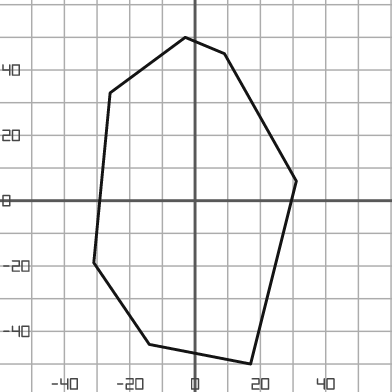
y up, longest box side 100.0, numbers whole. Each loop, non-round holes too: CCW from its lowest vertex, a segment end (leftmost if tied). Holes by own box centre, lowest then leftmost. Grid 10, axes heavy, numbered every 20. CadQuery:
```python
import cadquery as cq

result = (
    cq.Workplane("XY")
    .moveTo(17.0, -50.0)
    .lineTo(31.0, 6.0)
    .lineTo(9.0, 45.0)
    .lineTo(-3.0, 50.0)
    .lineTo(-26.0, 33.0)
    .lineTo(-31.0, -19.0)
    .lineTo(-14.0, -44.0)
    .close()
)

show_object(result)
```